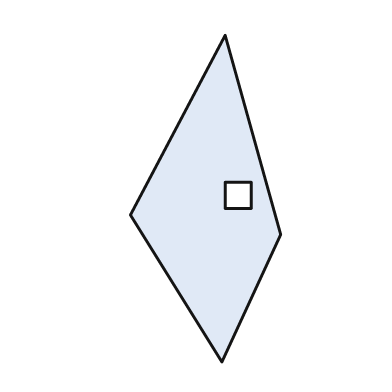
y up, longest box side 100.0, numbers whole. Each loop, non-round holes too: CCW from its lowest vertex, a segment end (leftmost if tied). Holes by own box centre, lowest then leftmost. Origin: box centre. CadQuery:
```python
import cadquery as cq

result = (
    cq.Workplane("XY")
    .moveTo(5.0, -50.0)
    .lineTo(23.0, -11.0)
    .lineTo(6.0, 50.0)
    .lineTo(-23.0, -5.0)
    .close()
    .moveTo(6.0, -3.0)
    .lineTo(14.0, -3.0)
    .lineTo(14.0, 5.0)
    .lineTo(6.0, 5.0)
    .close()
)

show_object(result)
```